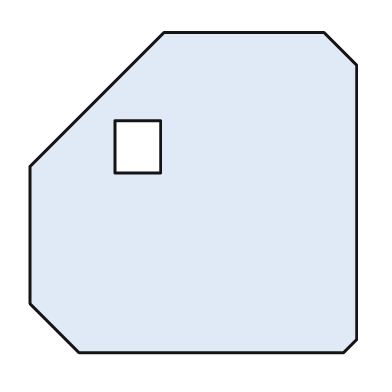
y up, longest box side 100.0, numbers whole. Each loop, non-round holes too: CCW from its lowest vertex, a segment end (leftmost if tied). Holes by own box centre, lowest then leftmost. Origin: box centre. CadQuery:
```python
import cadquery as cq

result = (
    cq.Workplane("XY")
    .moveTo(-35.0, -49.0)
    .lineTo(46.0, -49.0)
    .lineTo(50.0, -45.0)
    .lineTo(50.0, 39.0)
    .lineTo(40.0, 49.0)
    .lineTo(-9.0, 49.0)
    .lineTo(-50.0, 8.0)
    .lineTo(-50.0, -34.0)
    .close()
    .moveTo(-24.0, 6.0)
    .lineTo(-10.0, 6.0)
    .lineTo(-10.0, 22.0)
    .lineTo(-24.0, 22.0)
    .close()
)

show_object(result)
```